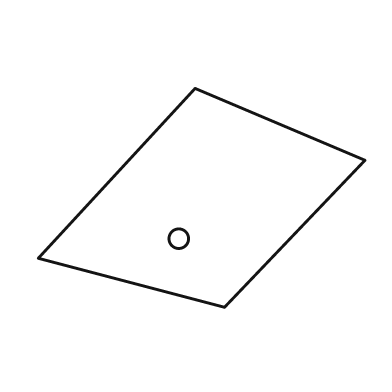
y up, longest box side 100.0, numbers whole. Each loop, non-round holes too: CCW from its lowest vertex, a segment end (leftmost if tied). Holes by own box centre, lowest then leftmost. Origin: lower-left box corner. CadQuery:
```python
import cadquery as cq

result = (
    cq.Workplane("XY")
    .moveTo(57.0, 0.0)
    .lineTo(100.0, 45.0)
    .lineTo(48.0, 67.0)
    .lineTo(0.0, 15.0)
    .close()
    .moveTo(43.0, 21.0)
    .circle(3.0)
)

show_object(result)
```